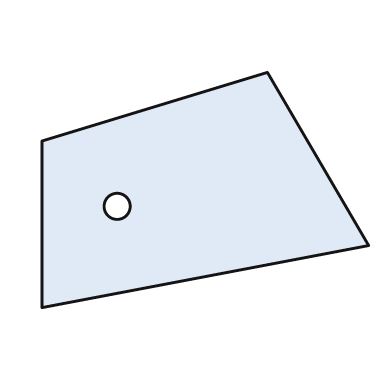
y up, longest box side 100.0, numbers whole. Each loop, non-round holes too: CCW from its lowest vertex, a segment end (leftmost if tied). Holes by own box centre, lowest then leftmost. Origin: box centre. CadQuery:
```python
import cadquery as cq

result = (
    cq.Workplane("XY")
    .moveTo(-50.0, -36.0)
    .lineTo(50.0, -17.0)
    .lineTo(19.0, 36.0)
    .lineTo(-50.0, 15.0)
    .close()
    .moveTo(-27.0, -5.0)
    .circle(4.0)
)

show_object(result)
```